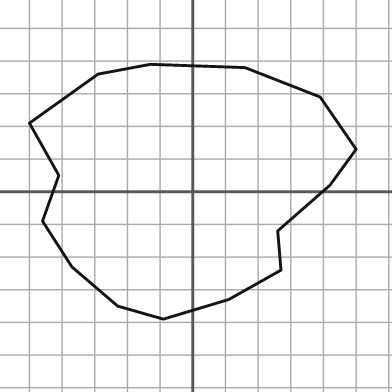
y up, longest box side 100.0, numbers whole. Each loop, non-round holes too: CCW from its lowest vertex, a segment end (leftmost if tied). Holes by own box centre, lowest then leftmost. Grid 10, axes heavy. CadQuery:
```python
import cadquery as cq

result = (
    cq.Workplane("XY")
    .moveTo(-9.0, -39.0)
    .lineTo(11.0, -33.0)
    .lineTo(27.0, -24.0)
    .lineTo(26.0, -12.0)
    .lineTo(42.0, 2.0)
    .lineTo(50.0, 13.0)
    .lineTo(39.0, 29.0)
    .lineTo(16.0, 38.0)
    .lineTo(-13.0, 39.0)
    .lineTo(-29.0, 36.0)
    .lineTo(-50.0, 21.0)
    .lineTo(-41.0, 5.0)
    .lineTo(-46.0, -9.0)
    .lineTo(-37.0, -23.0)
    .lineTo(-23.0, -35.0)
    .close()
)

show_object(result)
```